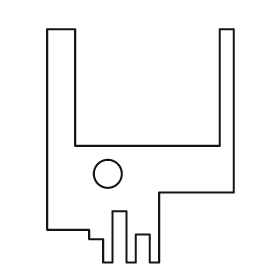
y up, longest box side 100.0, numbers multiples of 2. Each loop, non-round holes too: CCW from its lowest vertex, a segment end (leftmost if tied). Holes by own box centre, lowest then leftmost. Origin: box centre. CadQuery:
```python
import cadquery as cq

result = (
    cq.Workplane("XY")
    .moveTo(-16.0, -50.0)
    .lineTo(-12.0, -50.0)
    .lineTo(-12.0, -28.0)
    .lineTo(-6.0, -28.0)
    .lineTo(-6.0, -50.0)
    .lineTo(-2.0, -50.0)
    .lineTo(-2.0, -38.0)
    .lineTo(4.0, -38.0)
    .lineTo(4.0, -50.0)
    .lineTo(8.0, -50.0)
    .lineTo(8.0, -20.0)
    .lineTo(40.0, -20.0)
    .lineTo(40.0, 50.0)
    .lineTo(34.0, 50.0)
    .lineTo(34.0, 0.0)
    .lineTo(-28.0, 0.0)
    .lineTo(-28.0, 50.0)
    .lineTo(-40.0, 50.0)
    .lineTo(-40.0, -36.0)
    .lineTo(-22.0, -36.0)
    .lineTo(-22.0, -40.0)
    .lineTo(-16.0, -40.0)
    .close()
    .moveTo(-14.0, -12.0)
    .circle(6.0)
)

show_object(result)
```